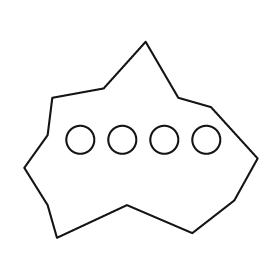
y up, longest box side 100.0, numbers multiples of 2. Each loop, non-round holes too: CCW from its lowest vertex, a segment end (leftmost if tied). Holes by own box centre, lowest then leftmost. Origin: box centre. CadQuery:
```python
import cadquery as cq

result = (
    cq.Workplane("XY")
    .moveTo(-36.0, -42.0)
    .lineTo(-6.0, -28.0)
    .lineTo(22.0, -40.0)
    .lineTo(40.0, -26.0)
    .lineTo(50.0, -8.0)
    .lineTo(30.0, 14.0)
    .lineTo(16.0, 18.0)
    .lineTo(2.0, 42.0)
    .lineTo(-16.0, 22.0)
    .lineTo(-38.0, 18.0)
    .lineTo(-40.0, 2.0)
    .lineTo(-50.0, -12.0)
    .lineTo(-40.0, -28.0)
    .close()
    .moveTo(-26.0, 0.0)
    .circle(6.0)
    .moveTo(-8.0, 0.0)
    .circle(6.0)
    .moveTo(10.0, 0.0)
    .circle(6.0)
    .moveTo(28.0, 0.0)
    .circle(6.0)
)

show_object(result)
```